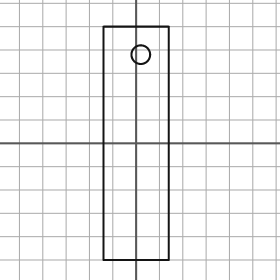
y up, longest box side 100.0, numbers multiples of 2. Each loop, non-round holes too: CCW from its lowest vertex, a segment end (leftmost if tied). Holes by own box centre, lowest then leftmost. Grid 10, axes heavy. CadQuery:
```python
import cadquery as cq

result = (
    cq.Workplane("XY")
    .moveTo(-14.0, -50.0)
    .lineTo(14.0, -50.0)
    .lineTo(14.0, 50.0)
    .lineTo(-14.0, 50.0)
    .close()
    .moveTo(2.0, 38.0)
    .circle(4.0)
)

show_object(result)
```